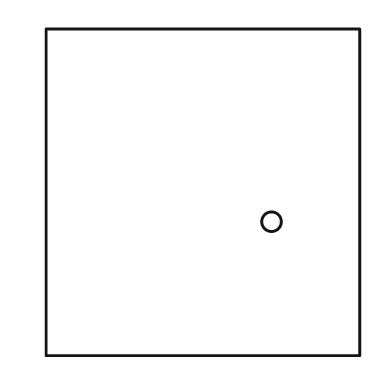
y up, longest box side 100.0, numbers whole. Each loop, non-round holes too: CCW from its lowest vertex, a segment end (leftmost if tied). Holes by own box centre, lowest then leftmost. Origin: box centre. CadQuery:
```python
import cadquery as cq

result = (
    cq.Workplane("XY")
    .moveTo(-48.0, -50.0)
    .lineTo(48.0, -50.0)
    .lineTo(48.0, 50.0)
    .lineTo(-48.0, 50.0)
    .close()
    .moveTo(21.0, -9.0)
    .circle(3.0)
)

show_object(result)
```